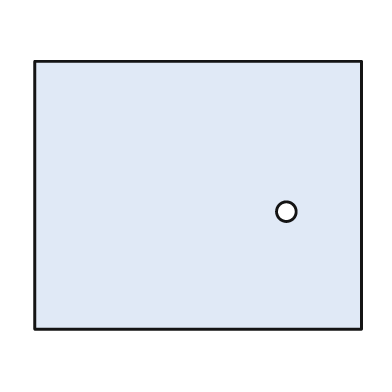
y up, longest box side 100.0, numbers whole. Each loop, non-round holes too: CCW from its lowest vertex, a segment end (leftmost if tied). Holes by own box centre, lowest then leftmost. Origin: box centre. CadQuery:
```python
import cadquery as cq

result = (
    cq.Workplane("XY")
    .moveTo(-50.0, -41.0)
    .lineTo(50.0, -41.0)
    .lineTo(50.0, 41.0)
    .lineTo(-50.0, 41.0)
    .close()
    .moveTo(27.0, -5.0)
    .circle(3.0)
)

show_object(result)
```